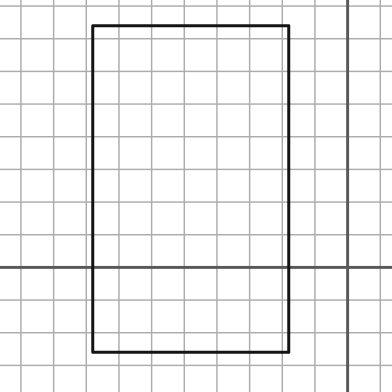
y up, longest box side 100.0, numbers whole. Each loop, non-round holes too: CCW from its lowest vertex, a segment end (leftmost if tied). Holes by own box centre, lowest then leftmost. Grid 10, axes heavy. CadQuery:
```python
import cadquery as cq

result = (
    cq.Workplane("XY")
    .moveTo(-78.0, -26.0)
    .lineTo(-18.0, -26.0)
    .lineTo(-18.0, 74.0)
    .lineTo(-78.0, 74.0)
    .close()
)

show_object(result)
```